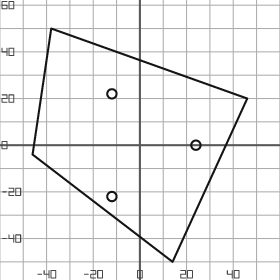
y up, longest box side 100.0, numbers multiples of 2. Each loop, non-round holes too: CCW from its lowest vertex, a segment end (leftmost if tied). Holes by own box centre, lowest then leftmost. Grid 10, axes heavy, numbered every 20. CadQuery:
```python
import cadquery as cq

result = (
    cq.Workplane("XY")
    .moveTo(14.0, -50.0)
    .lineTo(46.0, 20.0)
    .lineTo(-38.0, 50.0)
    .lineTo(-46.0, -4.0)
    .close()
    .moveTo(-12.0, -22.0)
    .circle(2.0)
    .moveTo(24.0, 0.0)
    .circle(2.0)
    .moveTo(-12.0, 22.0)
    .circle(2.0)
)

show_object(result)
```